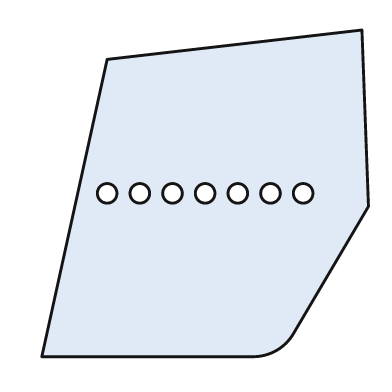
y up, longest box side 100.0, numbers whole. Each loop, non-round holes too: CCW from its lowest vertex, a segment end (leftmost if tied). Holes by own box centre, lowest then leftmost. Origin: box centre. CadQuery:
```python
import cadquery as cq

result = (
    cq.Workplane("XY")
    .moveTo(-50.0, -50.0)
    .lineTo(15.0, -50.0)
    .threePointArc((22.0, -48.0), (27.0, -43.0))
    .lineTo(50.0, -4.0)
    .lineTo(48.0, 50.0)
    .lineTo(-30.0, 41.0)
    .close()
    .moveTo(-30.0, 0.0)
    .circle(3.0)
    .moveTo(-20.0, 0.0)
    .circle(3.0)
    .moveTo(-10.0, 0.0)
    .circle(3.0)
    .moveTo(0.0, 0.0)
    .circle(3.0)
    .moveTo(10.0, 0.0)
    .circle(3.0)
    .moveTo(20.0, 0.0)
    .circle(3.0)
    .moveTo(30.0, 0.0)
    .circle(3.0)
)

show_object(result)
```